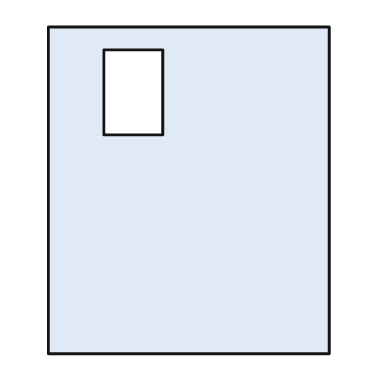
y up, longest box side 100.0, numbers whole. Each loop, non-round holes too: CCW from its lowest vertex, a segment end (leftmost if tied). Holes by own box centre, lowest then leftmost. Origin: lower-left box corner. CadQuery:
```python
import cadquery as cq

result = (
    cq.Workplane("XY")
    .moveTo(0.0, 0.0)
    .lineTo(86.0, 0.0)
    .lineTo(86.0, 100.0)
    .lineTo(0.0, 100.0)
    .close()
    .moveTo(17.0, 67.0)
    .lineTo(35.0, 67.0)
    .lineTo(35.0, 93.0)
    .lineTo(17.0, 93.0)
    .close()
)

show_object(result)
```